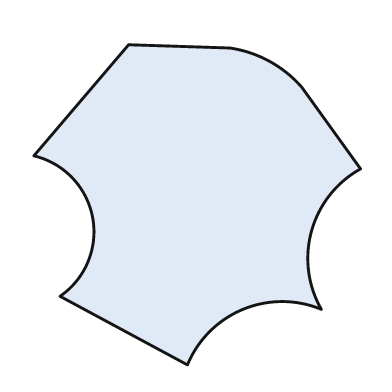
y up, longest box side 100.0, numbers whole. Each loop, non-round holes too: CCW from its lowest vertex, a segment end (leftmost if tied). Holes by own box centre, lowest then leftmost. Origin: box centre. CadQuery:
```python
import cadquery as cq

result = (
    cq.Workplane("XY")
    .moveTo(-3.0, -49.0)
    .threePointArc((14.0, -32.0), (38.0, -32.0))
    .threePointArc((35.0, -8.0), (50.0, 11.0))
    .lineTo(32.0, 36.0)
    .threePointArc((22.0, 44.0), (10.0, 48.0))
    .lineTo(-21.0, 49.0)
    .lineTo(-50.0, 15.0)
    .threePointArc((-32.0, -4.0), (-42.0, -28.0))
    .close()
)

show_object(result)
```